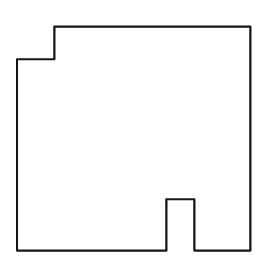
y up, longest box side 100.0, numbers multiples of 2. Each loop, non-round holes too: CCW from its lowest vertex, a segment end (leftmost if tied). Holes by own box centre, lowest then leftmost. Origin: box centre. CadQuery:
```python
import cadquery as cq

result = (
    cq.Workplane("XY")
    .moveTo(-50.0, -48.0)
    .lineTo(14.0, -48.0)
    .lineTo(14.0, -26.0)
    .lineTo(26.0, -26.0)
    .lineTo(26.0, -48.0)
    .lineTo(50.0, -48.0)
    .lineTo(50.0, 48.0)
    .lineTo(-34.0, 48.0)
    .lineTo(-34.0, 34.0)
    .lineTo(-50.0, 34.0)
    .close()
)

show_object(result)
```